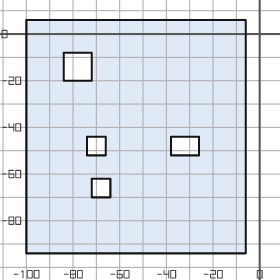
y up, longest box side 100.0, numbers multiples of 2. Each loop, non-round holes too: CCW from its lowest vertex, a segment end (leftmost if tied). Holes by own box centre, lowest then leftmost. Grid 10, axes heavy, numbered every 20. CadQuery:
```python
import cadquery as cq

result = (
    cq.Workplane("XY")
    .moveTo(-100.0, -94.0)
    .lineTo(-6.0, -94.0)
    .lineTo(-6.0, 6.0)
    .lineTo(-100.0, 6.0)
    .close()
    .moveTo(-72.0, -70.0)
    .lineTo(-64.0, -70.0)
    .lineTo(-64.0, -62.0)
    .lineTo(-72.0, -62.0)
    .close()
    .moveTo(-74.0, -52.0)
    .lineTo(-66.0, -52.0)
    .lineTo(-66.0, -44.0)
    .lineTo(-74.0, -44.0)
    .close()
    .moveTo(-38.0, -52.0)
    .lineTo(-26.0, -52.0)
    .lineTo(-26.0, -44.0)
    .lineTo(-38.0, -44.0)
    .close()
    .moveTo(-84.0, -20.0)
    .lineTo(-72.0, -20.0)
    .lineTo(-72.0, -8.0)
    .lineTo(-84.0, -8.0)
    .close()
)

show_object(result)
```